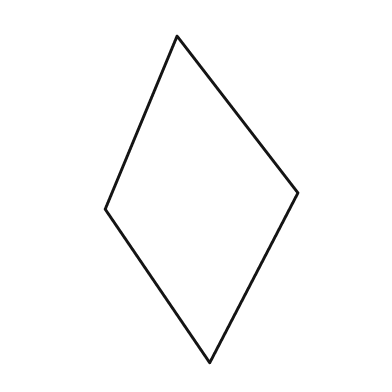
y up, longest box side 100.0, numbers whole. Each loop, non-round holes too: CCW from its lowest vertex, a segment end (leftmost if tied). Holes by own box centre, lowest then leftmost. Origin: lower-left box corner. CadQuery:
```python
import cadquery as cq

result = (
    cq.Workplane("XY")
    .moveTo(32.0, 0.0)
    .lineTo(59.0, 52.0)
    .lineTo(22.0, 100.0)
    .lineTo(0.0, 47.0)
    .close()
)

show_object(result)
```